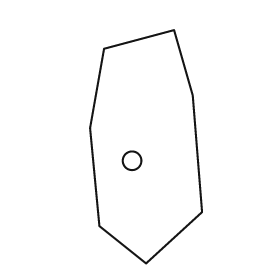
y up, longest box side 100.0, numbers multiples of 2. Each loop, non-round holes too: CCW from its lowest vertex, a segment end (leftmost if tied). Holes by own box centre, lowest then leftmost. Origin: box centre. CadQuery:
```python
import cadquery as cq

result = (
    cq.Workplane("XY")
    .moveTo(0.0, -50.0)
    .lineTo(24.0, -28.0)
    .lineTo(20.0, 22.0)
    .lineTo(12.0, 50.0)
    .lineTo(-18.0, 42.0)
    .lineTo(-24.0, 8.0)
    .lineTo(-20.0, -34.0)
    .close()
    .moveTo(-6.0, -6.0)
    .circle(4.0)
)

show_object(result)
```